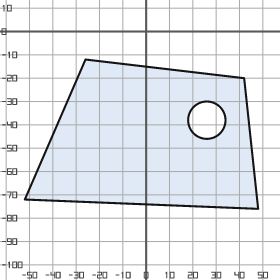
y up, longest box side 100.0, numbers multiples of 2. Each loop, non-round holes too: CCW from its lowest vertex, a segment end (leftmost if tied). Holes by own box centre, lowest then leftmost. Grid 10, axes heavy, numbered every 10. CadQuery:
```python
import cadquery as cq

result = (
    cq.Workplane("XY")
    .moveTo(48.0, -76.0)
    .lineTo(42.0, -20.0)
    .lineTo(-26.0, -12.0)
    .lineTo(-52.0, -72.0)
    .close()
    .moveTo(26.0, -38.0)
    .circle(8.0)
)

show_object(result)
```